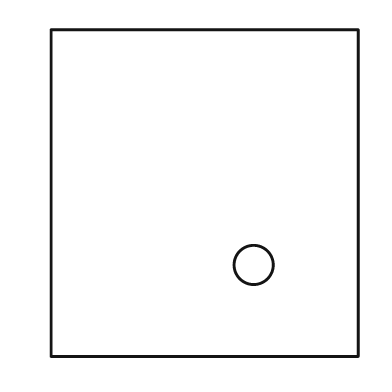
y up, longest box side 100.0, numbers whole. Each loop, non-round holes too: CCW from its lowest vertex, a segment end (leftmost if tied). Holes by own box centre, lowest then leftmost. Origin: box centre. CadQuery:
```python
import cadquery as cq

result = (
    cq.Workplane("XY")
    .moveTo(-47.0, -50.0)
    .lineTo(47.0, -50.0)
    .lineTo(47.0, 50.0)
    .lineTo(-47.0, 50.0)
    .close()
    .moveTo(15.0, -22.0)
    .circle(6.0)
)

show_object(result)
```